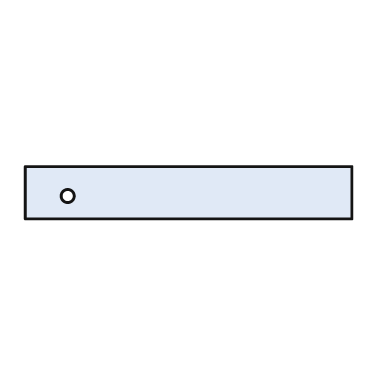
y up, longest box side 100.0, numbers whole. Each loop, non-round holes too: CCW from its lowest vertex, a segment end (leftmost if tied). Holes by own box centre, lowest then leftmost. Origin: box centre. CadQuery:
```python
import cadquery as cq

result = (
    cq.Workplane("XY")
    .moveTo(-50.0, -8.0)
    .lineTo(50.0, -8.0)
    .lineTo(50.0, 8.0)
    .lineTo(-50.0, 8.0)
    .close()
    .moveTo(-37.0, -1.0)
    .circle(2.0)
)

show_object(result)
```